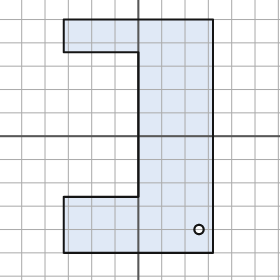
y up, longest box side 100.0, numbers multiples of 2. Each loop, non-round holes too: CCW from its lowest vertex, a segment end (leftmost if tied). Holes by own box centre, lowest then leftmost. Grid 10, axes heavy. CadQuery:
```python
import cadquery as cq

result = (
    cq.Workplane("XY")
    .moveTo(-32.0, -50.0)
    .lineTo(32.0, -50.0)
    .lineTo(32.0, 50.0)
    .lineTo(-32.0, 50.0)
    .lineTo(-32.0, 36.0)
    .lineTo(0.0, 36.0)
    .lineTo(0.0, -26.0)
    .lineTo(-32.0, -26.0)
    .close()
    .moveTo(26.0, -40.0)
    .circle(2.0)
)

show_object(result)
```